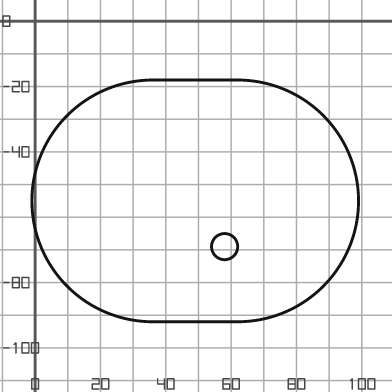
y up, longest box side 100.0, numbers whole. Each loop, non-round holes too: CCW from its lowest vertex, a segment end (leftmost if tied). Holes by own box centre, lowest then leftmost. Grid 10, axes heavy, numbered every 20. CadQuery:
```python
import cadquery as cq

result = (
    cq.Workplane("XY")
    .moveTo(36.0, -92.0)
    .lineTo(62.0, -92.0)
    .threePointArc((99.0, -55.0), (62.0, -18.0))
    .lineTo(36.0, -18.0)
    .threePointArc((-1.0, -55.0), (36.0, -92.0))
    .close()
    .moveTo(58.0, -69.0)
    .circle(4.0)
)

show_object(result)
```